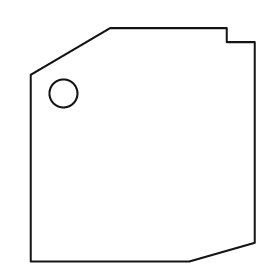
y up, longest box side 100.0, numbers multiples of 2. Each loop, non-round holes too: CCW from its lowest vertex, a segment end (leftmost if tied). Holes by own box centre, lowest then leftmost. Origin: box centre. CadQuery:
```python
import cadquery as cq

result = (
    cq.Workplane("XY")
    .moveTo(-48.0, -50.0)
    .lineTo(20.0, -50.0)
    .lineTo(48.0, -42.0)
    .lineTo(48.0, 44.0)
    .lineTo(36.0, 44.0)
    .lineTo(36.0, 50.0)
    .lineTo(-14.0, 50.0)
    .lineTo(-48.0, 30.0)
    .close()
    .moveTo(-34.0, 22.0)
    .circle(6.0)
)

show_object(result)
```